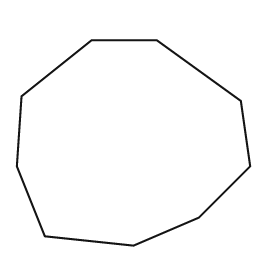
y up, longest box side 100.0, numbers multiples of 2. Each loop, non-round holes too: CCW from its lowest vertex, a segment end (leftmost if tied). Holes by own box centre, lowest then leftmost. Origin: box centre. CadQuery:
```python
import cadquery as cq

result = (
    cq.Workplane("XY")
    .moveTo(0.0, -44.0)
    .lineTo(28.0, -32.0)
    .lineTo(50.0, -10.0)
    .lineTo(46.0, 18.0)
    .lineTo(10.0, 44.0)
    .lineTo(-18.0, 44.0)
    .lineTo(-48.0, 20.0)
    .lineTo(-50.0, -10.0)
    .lineTo(-38.0, -40.0)
    .close()
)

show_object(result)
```